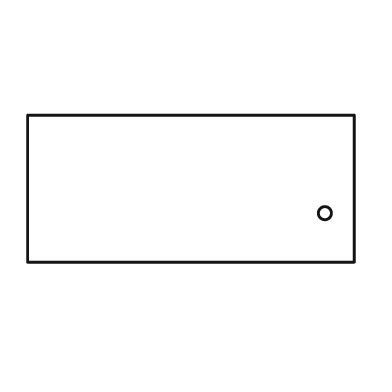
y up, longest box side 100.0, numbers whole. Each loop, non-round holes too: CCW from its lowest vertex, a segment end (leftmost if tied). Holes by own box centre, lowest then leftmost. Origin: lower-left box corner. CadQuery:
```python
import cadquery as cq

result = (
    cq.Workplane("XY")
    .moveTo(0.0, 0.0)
    .lineTo(100.0, 0.0)
    .lineTo(100.0, 45.0)
    .lineTo(0.0, 45.0)
    .close()
    .moveTo(91.0, 15.0)
    .circle(2.0)
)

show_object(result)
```